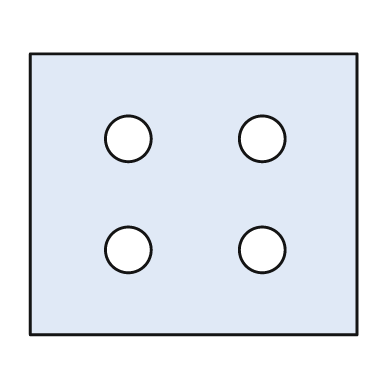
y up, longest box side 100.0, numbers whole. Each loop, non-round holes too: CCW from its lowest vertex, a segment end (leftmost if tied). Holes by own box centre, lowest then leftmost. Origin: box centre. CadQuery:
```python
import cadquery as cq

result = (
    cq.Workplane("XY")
    .moveTo(-50.0, -43.0)
    .lineTo(50.0, -43.0)
    .lineTo(50.0, 43.0)
    .lineTo(-50.0, 43.0)
    .close()
    .moveTo(-20.0, -17.0)
    .circle(7.0)
    .moveTo(21.0, -17.0)
    .circle(7.0)
    .moveTo(-20.0, 17.0)
    .circle(7.0)
    .moveTo(21.0, 17.0)
    .circle(7.0)
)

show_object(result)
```